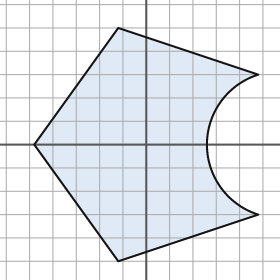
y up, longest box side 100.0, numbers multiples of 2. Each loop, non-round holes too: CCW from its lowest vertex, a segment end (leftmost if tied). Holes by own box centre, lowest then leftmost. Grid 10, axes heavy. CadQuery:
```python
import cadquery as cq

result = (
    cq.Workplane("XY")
    .moveTo(-12.0, -50.0)
    .lineTo(48.0, -30.0)
    .threePointArc((26.0, 0.0), (48.0, 30.0))
    .lineTo(-12.0, 50.0)
    .lineTo(-48.0, 0.0)
    .close()
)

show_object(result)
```